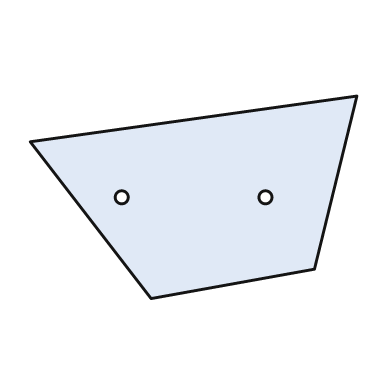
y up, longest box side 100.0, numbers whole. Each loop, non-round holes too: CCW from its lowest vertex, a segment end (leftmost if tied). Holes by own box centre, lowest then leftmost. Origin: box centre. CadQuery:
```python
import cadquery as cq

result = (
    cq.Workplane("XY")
    .moveTo(-13.0, -31.0)
    .lineTo(37.0, -22.0)
    .lineTo(50.0, 31.0)
    .lineTo(-50.0, 17.0)
    .close()
    .moveTo(-22.0, 0.0)
    .circle(2.0)
    .moveTo(22.0, 0.0)
    .circle(2.0)
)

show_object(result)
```